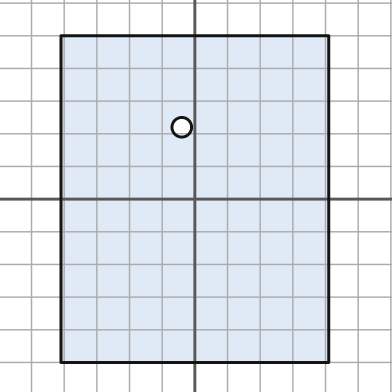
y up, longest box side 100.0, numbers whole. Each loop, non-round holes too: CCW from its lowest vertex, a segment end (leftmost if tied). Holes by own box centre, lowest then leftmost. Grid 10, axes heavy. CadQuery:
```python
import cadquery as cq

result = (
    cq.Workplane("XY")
    .moveTo(-41.0, -50.0)
    .lineTo(41.0, -50.0)
    .lineTo(41.0, 50.0)
    .lineTo(-41.0, 50.0)
    .close()
    .moveTo(-4.0, 22.0)
    .circle(3.0)
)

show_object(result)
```